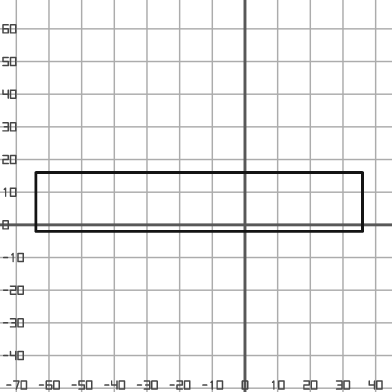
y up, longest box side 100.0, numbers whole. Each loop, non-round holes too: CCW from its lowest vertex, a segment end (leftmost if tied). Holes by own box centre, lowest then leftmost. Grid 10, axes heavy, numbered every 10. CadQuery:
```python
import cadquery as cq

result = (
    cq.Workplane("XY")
    .moveTo(-64.0, -2.0)
    .lineTo(36.0, -2.0)
    .lineTo(36.0, 16.0)
    .lineTo(-64.0, 16.0)
    .close()
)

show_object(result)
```